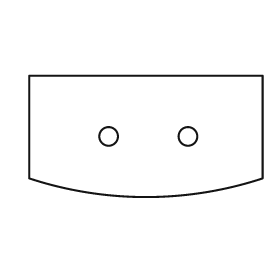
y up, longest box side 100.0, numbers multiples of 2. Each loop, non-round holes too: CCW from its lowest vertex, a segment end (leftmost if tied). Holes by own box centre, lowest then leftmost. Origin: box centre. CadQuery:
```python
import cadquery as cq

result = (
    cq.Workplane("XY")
    .moveTo(-50.0, -18.0)
    .threePointArc((0.0, -26.0), (50.0, -18.0))
    .lineTo(50.0, 26.0)
    .lineTo(-50.0, 26.0)
    .close()
    .moveTo(-16.0, 0.0)
    .circle(4.0)
    .moveTo(18.0, 0.0)
    .circle(4.0)
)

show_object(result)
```